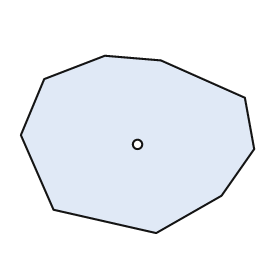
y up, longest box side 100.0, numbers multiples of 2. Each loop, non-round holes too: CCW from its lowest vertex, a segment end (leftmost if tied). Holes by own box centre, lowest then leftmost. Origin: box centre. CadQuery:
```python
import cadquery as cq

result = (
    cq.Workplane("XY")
    .moveTo(8.0, -38.0)
    .lineTo(36.0, -22.0)
    .lineTo(50.0, -2.0)
    .lineTo(46.0, 20.0)
    .lineTo(10.0, 36.0)
    .lineTo(-14.0, 38.0)
    .lineTo(-40.0, 28.0)
    .lineTo(-50.0, 4.0)
    .lineTo(-36.0, -28.0)
    .close()
    .moveTo(0.0, 0.0)
    .circle(2.0)
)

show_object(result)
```